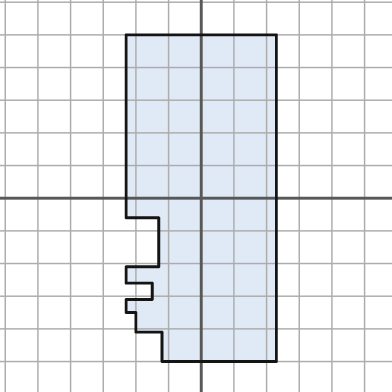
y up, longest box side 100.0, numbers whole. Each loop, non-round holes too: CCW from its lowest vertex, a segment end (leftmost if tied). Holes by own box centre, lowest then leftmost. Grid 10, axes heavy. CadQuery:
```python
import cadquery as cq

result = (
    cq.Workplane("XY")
    .moveTo(-12.0, -50.0)
    .lineTo(23.0, -50.0)
    .lineTo(23.0, 50.0)
    .lineTo(-23.0, 50.0)
    .lineTo(-23.0, -6.0)
    .lineTo(-13.0, -6.0)
    .lineTo(-13.0, -21.0)
    .lineTo(-23.0, -21.0)
    .lineTo(-23.0, -26.0)
    .lineTo(-15.0, -26.0)
    .lineTo(-15.0, -31.0)
    .lineTo(-23.0, -31.0)
    .lineTo(-23.0, -35.0)
    .lineTo(-20.0, -35.0)
    .lineTo(-20.0, -41.0)
    .lineTo(-12.0, -41.0)
    .close()
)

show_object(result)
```